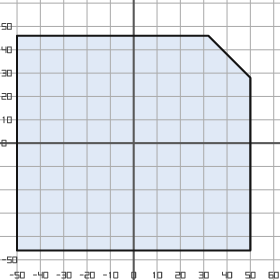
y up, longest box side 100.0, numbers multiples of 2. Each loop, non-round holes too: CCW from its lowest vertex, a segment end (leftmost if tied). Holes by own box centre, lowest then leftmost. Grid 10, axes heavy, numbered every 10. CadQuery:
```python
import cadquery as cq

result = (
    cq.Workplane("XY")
    .moveTo(-50.0, -46.0)
    .lineTo(50.0, -46.0)
    .lineTo(50.0, 28.0)
    .lineTo(32.0, 46.0)
    .lineTo(-50.0, 46.0)
    .close()
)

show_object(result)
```